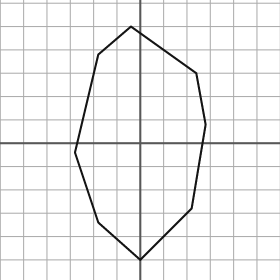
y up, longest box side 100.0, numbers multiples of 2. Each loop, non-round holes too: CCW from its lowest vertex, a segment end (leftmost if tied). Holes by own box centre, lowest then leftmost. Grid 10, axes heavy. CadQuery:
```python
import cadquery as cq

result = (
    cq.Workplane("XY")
    .moveTo(0.0, -50.0)
    .lineTo(22.0, -28.0)
    .lineTo(28.0, 8.0)
    .lineTo(24.0, 30.0)
    .lineTo(-4.0, 50.0)
    .lineTo(-18.0, 38.0)
    .lineTo(-28.0, -4.0)
    .lineTo(-18.0, -34.0)
    .close()
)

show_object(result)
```